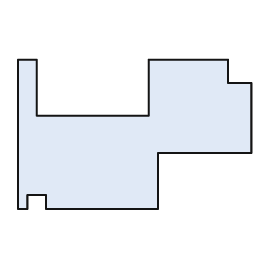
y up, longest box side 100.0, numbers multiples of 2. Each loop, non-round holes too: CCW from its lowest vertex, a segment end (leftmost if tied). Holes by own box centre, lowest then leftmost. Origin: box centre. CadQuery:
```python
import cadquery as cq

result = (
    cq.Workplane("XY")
    .moveTo(-50.0, -32.0)
    .lineTo(-46.0, -32.0)
    .lineTo(-46.0, -26.0)
    .lineTo(-38.0, -26.0)
    .lineTo(-38.0, -32.0)
    .lineTo(10.0, -32.0)
    .lineTo(10.0, -8.0)
    .lineTo(50.0, -8.0)
    .lineTo(50.0, 22.0)
    .lineTo(40.0, 22.0)
    .lineTo(40.0, 32.0)
    .lineTo(6.0, 32.0)
    .lineTo(6.0, 8.0)
    .lineTo(-42.0, 8.0)
    .lineTo(-42.0, 32.0)
    .lineTo(-50.0, 32.0)
    .close()
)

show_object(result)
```